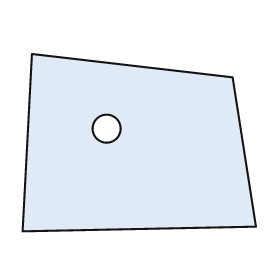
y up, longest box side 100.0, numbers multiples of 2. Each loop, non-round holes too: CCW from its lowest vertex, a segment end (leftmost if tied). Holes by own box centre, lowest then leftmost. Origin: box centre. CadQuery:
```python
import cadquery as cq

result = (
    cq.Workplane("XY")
    .moveTo(-50.0, -38.0)
    .lineTo(50.0, -36.0)
    .lineTo(40.0, 28.0)
    .lineTo(-46.0, 38.0)
    .close()
    .moveTo(-14.0, 6.0)
    .circle(6.0)
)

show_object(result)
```